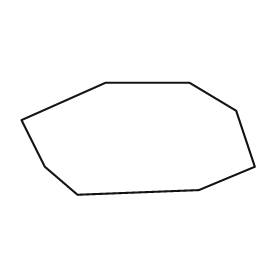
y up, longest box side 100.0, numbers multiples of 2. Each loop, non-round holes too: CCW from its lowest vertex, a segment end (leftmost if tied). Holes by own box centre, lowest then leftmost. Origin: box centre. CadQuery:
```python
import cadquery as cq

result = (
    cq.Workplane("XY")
    .moveTo(-26.0, -24.0)
    .lineTo(26.0, -22.0)
    .lineTo(50.0, -12.0)
    .lineTo(42.0, 12.0)
    .lineTo(22.0, 24.0)
    .lineTo(-14.0, 24.0)
    .lineTo(-50.0, 8.0)
    .lineTo(-40.0, -12.0)
    .close()
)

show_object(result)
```